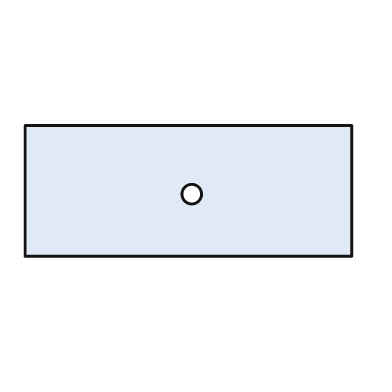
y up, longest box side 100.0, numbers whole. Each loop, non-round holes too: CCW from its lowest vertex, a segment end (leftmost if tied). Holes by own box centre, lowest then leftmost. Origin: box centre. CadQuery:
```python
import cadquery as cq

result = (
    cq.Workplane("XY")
    .moveTo(-50.0, -20.0)
    .lineTo(50.0, -20.0)
    .lineTo(50.0, 20.0)
    .lineTo(-50.0, 20.0)
    .close()
    .moveTo(1.0, -1.0)
    .circle(3.0)
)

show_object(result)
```